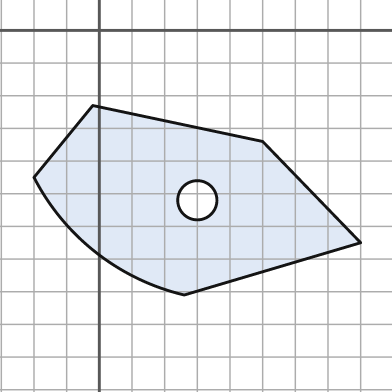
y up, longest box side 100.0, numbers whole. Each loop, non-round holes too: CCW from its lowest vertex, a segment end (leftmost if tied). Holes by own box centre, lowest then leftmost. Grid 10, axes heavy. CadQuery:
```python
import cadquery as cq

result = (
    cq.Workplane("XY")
    .moveTo(26.0, -81.0)
    .lineTo(80.0, -65.0)
    .lineTo(50.0, -34.0)
    .lineTo(-2.0, -23.0)
    .lineTo(-20.0, -45.0)
    .threePointArc((-1.0, -68.0), (26.0, -81.0))
    .close()
    .moveTo(30.0, -52.0)
    .circle(6.0)
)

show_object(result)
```